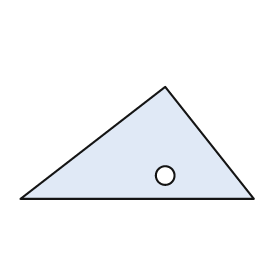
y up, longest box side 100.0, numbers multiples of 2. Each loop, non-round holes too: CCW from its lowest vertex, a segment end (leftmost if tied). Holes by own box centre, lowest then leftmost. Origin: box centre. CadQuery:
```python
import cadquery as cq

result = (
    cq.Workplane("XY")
    .moveTo(-50.0, -24.0)
    .lineTo(50.0, -24.0)
    .lineTo(12.0, 24.0)
    .close()
    .moveTo(12.0, -14.0)
    .circle(4.0)
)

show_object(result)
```